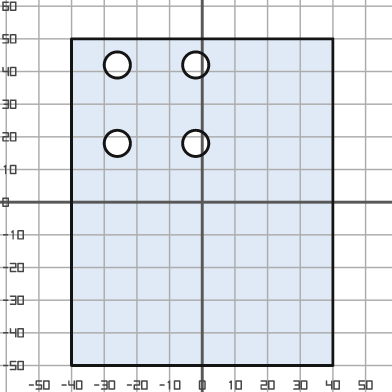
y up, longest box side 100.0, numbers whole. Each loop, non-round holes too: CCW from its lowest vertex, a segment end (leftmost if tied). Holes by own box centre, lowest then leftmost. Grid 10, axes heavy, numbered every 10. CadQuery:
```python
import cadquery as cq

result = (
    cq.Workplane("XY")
    .moveTo(-40.0, -50.0)
    .lineTo(40.0, -50.0)
    .lineTo(40.0, 50.0)
    .lineTo(-40.0, 50.0)
    .close()
    .moveTo(-26.0, 18.0)
    .circle(4.0)
    .moveTo(-2.0, 18.0)
    .circle(4.0)
    .moveTo(-26.0, 42.0)
    .circle(4.0)
    .moveTo(-2.0, 42.0)
    .circle(4.0)
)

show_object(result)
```